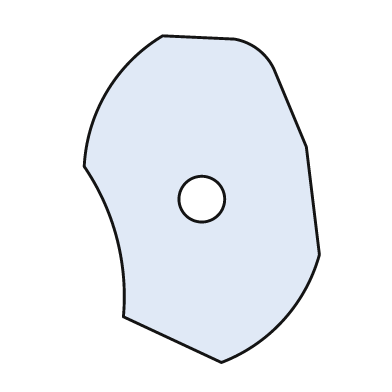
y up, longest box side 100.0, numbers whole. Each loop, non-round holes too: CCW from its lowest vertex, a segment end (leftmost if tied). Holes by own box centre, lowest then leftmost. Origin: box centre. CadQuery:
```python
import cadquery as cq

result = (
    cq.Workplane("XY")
    .moveTo(6.0, -50.0)
    .threePointArc((25.0, -37.0), (36.0, -17.0))
    .lineTo(32.0, 16.0)
    .lineTo(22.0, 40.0)
    .threePointArc((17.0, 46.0), (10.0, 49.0))
    .lineTo(-12.0, 50.0)
    .threePointArc((-29.0, 33.0), (-36.0, 10.0))
    .threePointArc((-26.0, -12.0), (-24.0, -36.0))
    .close()
    .moveTo(0.0, 0.0)
    .circle(7.0)
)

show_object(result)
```